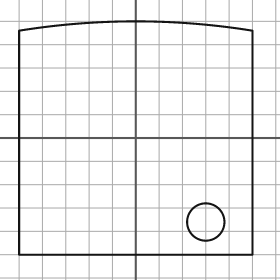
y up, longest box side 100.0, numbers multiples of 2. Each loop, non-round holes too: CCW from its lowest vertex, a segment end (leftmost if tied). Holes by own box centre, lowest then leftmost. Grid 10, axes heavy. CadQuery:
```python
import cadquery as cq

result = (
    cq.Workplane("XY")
    .moveTo(-50.0, -50.0)
    .lineTo(50.0, -50.0)
    .lineTo(50.0, 46.0)
    .threePointArc((0.0, 50.0), (-50.0, 46.0))
    .close()
    .moveTo(30.0, -36.0)
    .circle(8.0)
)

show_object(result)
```